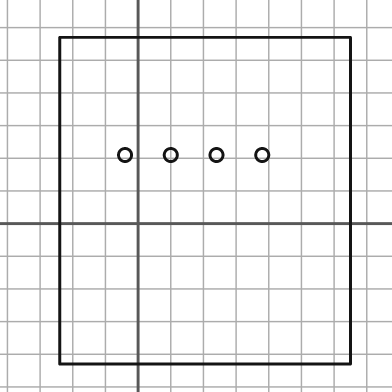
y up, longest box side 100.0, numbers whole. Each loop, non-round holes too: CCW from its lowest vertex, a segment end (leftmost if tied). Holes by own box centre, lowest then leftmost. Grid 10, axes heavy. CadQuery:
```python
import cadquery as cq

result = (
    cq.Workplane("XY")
    .moveTo(-24.0, -43.0)
    .lineTo(65.0, -43.0)
    .lineTo(65.0, 57.0)
    .lineTo(-24.0, 57.0)
    .close()
    .moveTo(-4.0, 21.0)
    .circle(2.0)
    .moveTo(10.0, 21.0)
    .circle(2.0)
    .moveTo(24.0, 21.0)
    .circle(2.0)
    .moveTo(38.0, 21.0)
    .circle(2.0)
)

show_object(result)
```